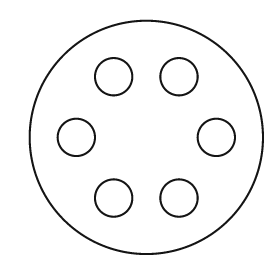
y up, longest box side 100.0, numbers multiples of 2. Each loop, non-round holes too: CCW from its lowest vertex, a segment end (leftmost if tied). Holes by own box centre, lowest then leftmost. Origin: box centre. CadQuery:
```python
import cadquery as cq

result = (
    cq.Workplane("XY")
    .moveTo(0.0, 0.0)
    .circle(50.0)
    .moveTo(-14.0, -26.0)
    .circle(8.0)
    .moveTo(14.0, -26.0)
    .circle(8.0)
    .moveTo(-30.0, 0.0)
    .circle(8.0)
    .moveTo(30.0, 0.0)
    .circle(8.0)
    .moveTo(-14.0, 26.0)
    .circle(8.0)
    .moveTo(14.0, 26.0)
    .circle(8.0)
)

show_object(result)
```